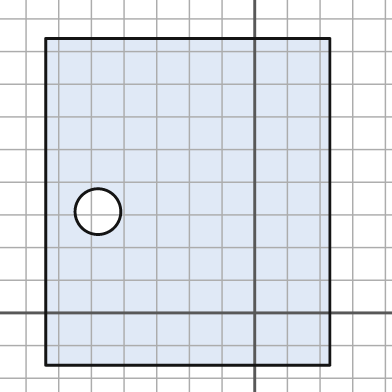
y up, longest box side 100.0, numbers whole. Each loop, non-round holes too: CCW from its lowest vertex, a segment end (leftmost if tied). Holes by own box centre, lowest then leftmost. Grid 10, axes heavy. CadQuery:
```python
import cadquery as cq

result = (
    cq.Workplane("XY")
    .moveTo(-64.0, -16.0)
    .lineTo(23.0, -16.0)
    .lineTo(23.0, 84.0)
    .lineTo(-64.0, 84.0)
    .close()
    .moveTo(-48.0, 31.0)
    .circle(7.0)
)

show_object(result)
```